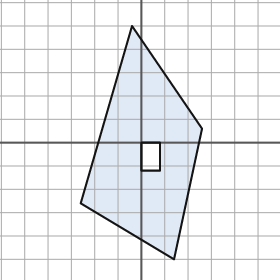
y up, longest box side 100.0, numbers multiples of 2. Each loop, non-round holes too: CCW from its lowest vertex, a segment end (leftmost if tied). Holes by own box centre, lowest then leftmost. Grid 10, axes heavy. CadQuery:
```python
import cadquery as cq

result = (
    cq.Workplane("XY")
    .moveTo(14.0, -50.0)
    .lineTo(26.0, 6.0)
    .lineTo(-4.0, 50.0)
    .lineTo(-26.0, -26.0)
    .close()
    .moveTo(0.0, -12.0)
    .lineTo(8.0, -12.0)
    .lineTo(8.0, 0.0)
    .lineTo(0.0, 0.0)
    .close()
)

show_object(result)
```